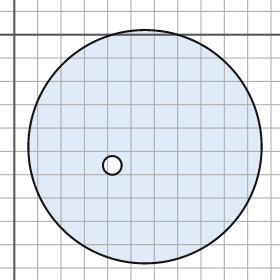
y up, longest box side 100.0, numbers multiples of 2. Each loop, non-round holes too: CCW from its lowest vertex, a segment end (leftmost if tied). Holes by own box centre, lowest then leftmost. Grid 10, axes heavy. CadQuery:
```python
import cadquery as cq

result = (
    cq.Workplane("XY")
    .moveTo(56.0, -48.0)
    .circle(50.0)
    .moveTo(42.0, -56.0)
    .circle(4.0)
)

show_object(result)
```